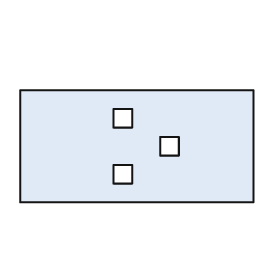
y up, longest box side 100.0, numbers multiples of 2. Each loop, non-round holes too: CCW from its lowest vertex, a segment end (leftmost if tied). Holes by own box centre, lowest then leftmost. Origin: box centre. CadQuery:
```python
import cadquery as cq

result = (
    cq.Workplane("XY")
    .moveTo(-50.0, -24.0)
    .lineTo(50.0, -24.0)
    .lineTo(50.0, 24.0)
    .lineTo(-50.0, 24.0)
    .close()
    .moveTo(-10.0, -16.0)
    .lineTo(-2.0, -16.0)
    .lineTo(-2.0, -8.0)
    .lineTo(-10.0, -8.0)
    .close()
    .moveTo(10.0, -4.0)
    .lineTo(18.0, -4.0)
    .lineTo(18.0, 4.0)
    .lineTo(10.0, 4.0)
    .close()
    .moveTo(-10.0, 8.0)
    .lineTo(-2.0, 8.0)
    .lineTo(-2.0, 16.0)
    .lineTo(-10.0, 16.0)
    .close()
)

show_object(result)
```